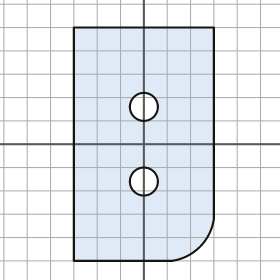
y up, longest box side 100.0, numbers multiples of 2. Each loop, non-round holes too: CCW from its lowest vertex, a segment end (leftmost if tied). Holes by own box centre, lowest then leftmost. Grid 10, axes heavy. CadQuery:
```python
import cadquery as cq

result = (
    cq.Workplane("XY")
    .moveTo(-30.0, -50.0)
    .lineTo(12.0, -50.0)
    .threePointArc((24.0, -44.0), (30.0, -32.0))
    .lineTo(30.0, 50.0)
    .lineTo(-30.0, 50.0)
    .close()
    .moveTo(0.0, -16.0)
    .circle(6.0)
    .moveTo(0.0, 16.0)
    .circle(6.0)
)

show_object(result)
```